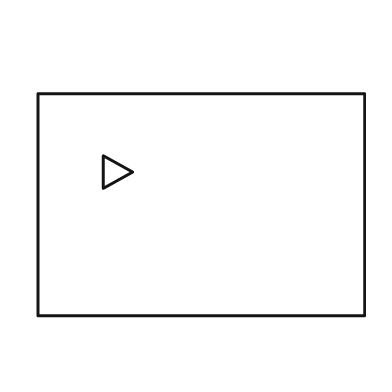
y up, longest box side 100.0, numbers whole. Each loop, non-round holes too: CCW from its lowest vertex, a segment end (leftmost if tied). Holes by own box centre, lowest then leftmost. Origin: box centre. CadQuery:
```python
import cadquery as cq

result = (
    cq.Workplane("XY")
    .moveTo(-50.0, -34.0)
    .lineTo(50.0, -34.0)
    .lineTo(50.0, 34.0)
    .lineTo(-50.0, 34.0)
    .close()
    .moveTo(-30.0, 5.0)
    .lineTo(-21.0, 10.0)
    .lineTo(-30.0, 15.0)
    .close()
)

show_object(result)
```